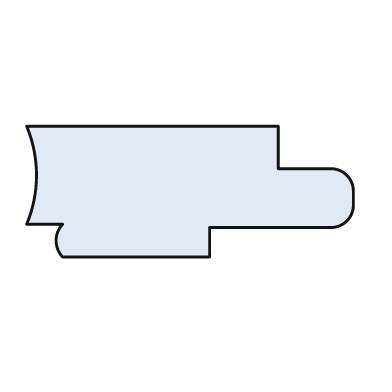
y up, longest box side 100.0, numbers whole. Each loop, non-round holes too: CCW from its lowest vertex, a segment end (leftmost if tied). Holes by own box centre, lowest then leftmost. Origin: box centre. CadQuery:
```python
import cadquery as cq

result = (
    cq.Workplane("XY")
    .moveTo(-39.0, -20.0)
    .lineTo(6.0, -20.0)
    .lineTo(6.0, -11.0)
    .lineTo(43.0, -11.0)
    .threePointArc((48.0, -9.0), (50.0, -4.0))
    .lineTo(50.0, 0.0)
    .threePointArc((48.0, 5.0), (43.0, 7.0))
    .lineTo(27.0, 7.0)
    .lineTo(27.0, 20.0)
    .lineTo(-50.0, 20.0)
    .threePointArc((-47.0, 5.0), (-50.0, -10.0))
    .lineTo(-39.0, -10.0)
    .threePointArc((-41.0, -15.0), (-39.0, -20.0))
    .close()
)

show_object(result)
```